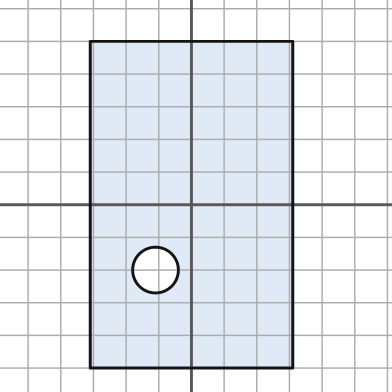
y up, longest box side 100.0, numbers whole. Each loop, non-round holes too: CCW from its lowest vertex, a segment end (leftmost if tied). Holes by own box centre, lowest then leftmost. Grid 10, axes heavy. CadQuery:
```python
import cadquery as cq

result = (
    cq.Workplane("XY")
    .moveTo(-31.0, -50.0)
    .lineTo(31.0, -50.0)
    .lineTo(31.0, 50.0)
    .lineTo(-31.0, 50.0)
    .close()
    .moveTo(-11.0, -20.0)
    .circle(7.0)
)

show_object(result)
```